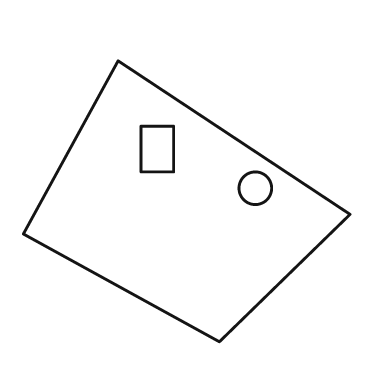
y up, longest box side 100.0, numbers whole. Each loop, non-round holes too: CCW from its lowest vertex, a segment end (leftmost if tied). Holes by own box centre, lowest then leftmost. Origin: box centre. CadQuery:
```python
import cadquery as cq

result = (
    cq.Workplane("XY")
    .moveTo(10.0, -43.0)
    .lineTo(50.0, -4.0)
    .lineTo(-21.0, 43.0)
    .lineTo(-50.0, -10.0)
    .close()
    .moveTo(21.0, 4.0)
    .circle(5.0)
    .moveTo(-14.0, 9.0)
    .lineTo(-4.0, 9.0)
    .lineTo(-4.0, 23.0)
    .lineTo(-14.0, 23.0)
    .close()
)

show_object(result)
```